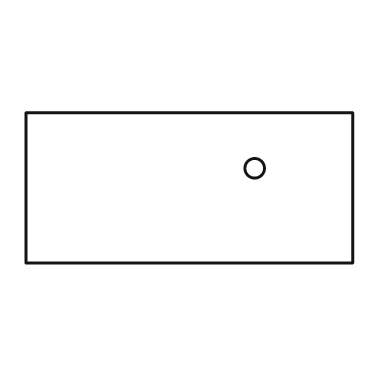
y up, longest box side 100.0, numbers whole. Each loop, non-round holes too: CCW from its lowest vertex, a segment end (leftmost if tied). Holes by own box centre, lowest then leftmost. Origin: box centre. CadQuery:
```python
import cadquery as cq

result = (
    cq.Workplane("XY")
    .moveTo(-50.0, -23.0)
    .lineTo(50.0, -23.0)
    .lineTo(50.0, 23.0)
    .lineTo(-50.0, 23.0)
    .close()
    .moveTo(20.0, 6.0)
    .circle(3.0)
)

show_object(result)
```